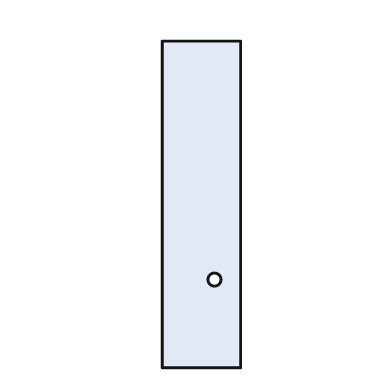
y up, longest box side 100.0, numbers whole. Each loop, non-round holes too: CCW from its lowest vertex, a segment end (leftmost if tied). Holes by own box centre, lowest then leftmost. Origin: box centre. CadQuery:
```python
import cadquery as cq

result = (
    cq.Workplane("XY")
    .moveTo(-12.0, -50.0)
    .lineTo(12.0, -50.0)
    .lineTo(12.0, 50.0)
    .lineTo(-12.0, 50.0)
    .close()
    .moveTo(4.0, -23.0)
    .circle(2.0)
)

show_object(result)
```